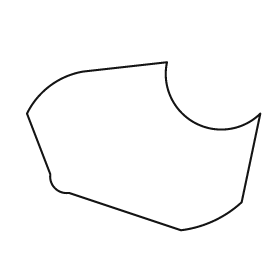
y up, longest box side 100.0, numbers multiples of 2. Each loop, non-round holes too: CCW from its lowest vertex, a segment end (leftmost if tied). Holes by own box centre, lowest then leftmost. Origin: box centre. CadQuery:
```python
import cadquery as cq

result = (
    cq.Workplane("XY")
    .moveTo(16.0, -36.0)
    .threePointArc((30.0, -32.0), (42.0, -24.0))
    .lineTo(50.0, 14.0)
    .threePointArc((22.0, 10.0), (10.0, 36.0))
    .lineTo(-26.0, 32.0)
    .threePointArc((-40.0, 26.0), (-50.0, 14.0))
    .lineTo(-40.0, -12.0)
    .threePointArc((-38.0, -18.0), (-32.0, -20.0))
    .close()
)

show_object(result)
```